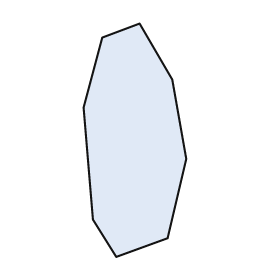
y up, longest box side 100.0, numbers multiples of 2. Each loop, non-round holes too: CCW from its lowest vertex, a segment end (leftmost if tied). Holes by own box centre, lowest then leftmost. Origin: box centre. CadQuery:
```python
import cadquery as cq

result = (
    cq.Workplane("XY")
    .moveTo(-8.0, -50.0)
    .lineTo(14.0, -42.0)
    .lineTo(22.0, -8.0)
    .lineTo(16.0, 26.0)
    .lineTo(2.0, 50.0)
    .lineTo(-14.0, 44.0)
    .lineTo(-22.0, 14.0)
    .lineTo(-18.0, -34.0)
    .close()
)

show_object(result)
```